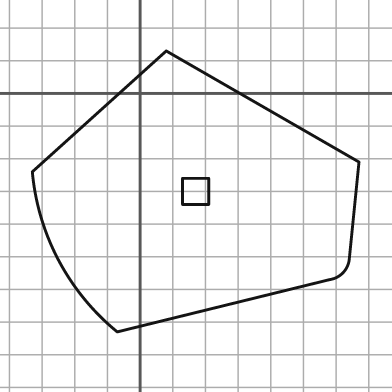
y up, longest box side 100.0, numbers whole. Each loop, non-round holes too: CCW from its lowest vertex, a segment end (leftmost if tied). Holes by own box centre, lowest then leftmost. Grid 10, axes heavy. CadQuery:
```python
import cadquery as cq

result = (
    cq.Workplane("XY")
    .moveTo(-7.0, -73.0)
    .lineTo(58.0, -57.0)
    .threePointArc((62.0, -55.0), (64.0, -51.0))
    .lineTo(67.0, -21.0)
    .lineTo(8.0, 13.0)
    .lineTo(-33.0, -24.0)
    .threePointArc((-25.0, -51.0), (-7.0, -73.0))
    .close()
    .moveTo(13.0, -34.0)
    .lineTo(21.0, -34.0)
    .lineTo(21.0, -26.0)
    .lineTo(13.0, -26.0)
    .close()
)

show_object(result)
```